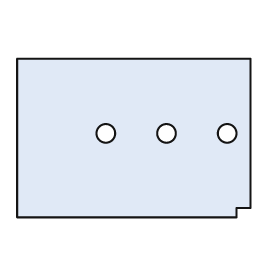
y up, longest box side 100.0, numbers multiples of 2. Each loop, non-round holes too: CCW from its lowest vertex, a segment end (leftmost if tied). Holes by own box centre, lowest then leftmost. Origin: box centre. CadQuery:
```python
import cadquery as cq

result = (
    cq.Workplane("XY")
    .moveTo(-50.0, -34.0)
    .lineTo(44.0, -34.0)
    .lineTo(44.0, -30.0)
    .lineTo(50.0, -30.0)
    .lineTo(50.0, 34.0)
    .lineTo(-50.0, 34.0)
    .close()
    .moveTo(-12.0, 2.0)
    .circle(4.0)
    .moveTo(14.0, 2.0)
    .circle(4.0)
    .moveTo(40.0, 2.0)
    .circle(4.0)
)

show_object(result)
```